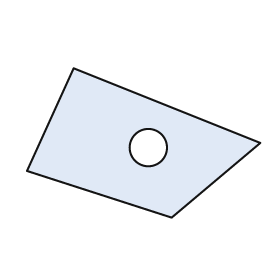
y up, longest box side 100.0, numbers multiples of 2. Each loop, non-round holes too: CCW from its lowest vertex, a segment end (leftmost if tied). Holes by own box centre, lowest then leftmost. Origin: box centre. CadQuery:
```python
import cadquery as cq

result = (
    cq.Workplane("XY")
    .moveTo(12.0, -32.0)
    .lineTo(50.0, 0.0)
    .lineTo(-30.0, 32.0)
    .lineTo(-50.0, -12.0)
    .close()
    .moveTo(2.0, -2.0)
    .circle(8.0)
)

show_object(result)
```